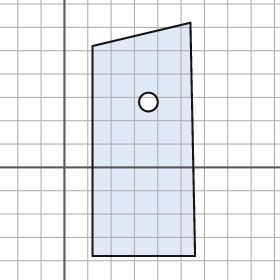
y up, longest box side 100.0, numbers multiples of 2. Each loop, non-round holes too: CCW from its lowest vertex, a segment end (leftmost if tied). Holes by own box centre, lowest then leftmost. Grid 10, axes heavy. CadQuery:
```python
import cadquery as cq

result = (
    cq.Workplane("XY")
    .moveTo(12.0, -38.0)
    .lineTo(56.0, -38.0)
    .lineTo(54.0, 62.0)
    .lineTo(12.0, 52.0)
    .close()
    .moveTo(36.0, 28.0)
    .circle(4.0)
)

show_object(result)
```